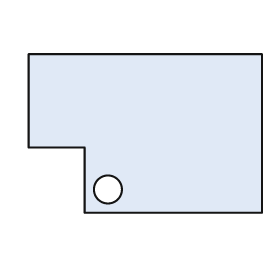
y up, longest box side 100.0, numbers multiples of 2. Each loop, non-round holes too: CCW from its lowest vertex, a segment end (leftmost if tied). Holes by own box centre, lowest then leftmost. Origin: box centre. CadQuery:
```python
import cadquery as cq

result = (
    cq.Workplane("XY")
    .moveTo(-26.0, -34.0)
    .lineTo(50.0, -34.0)
    .lineTo(50.0, 34.0)
    .lineTo(-50.0, 34.0)
    .lineTo(-50.0, -6.0)
    .lineTo(-26.0, -6.0)
    .close()
    .moveTo(-16.0, -24.0)
    .circle(6.0)
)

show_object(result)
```